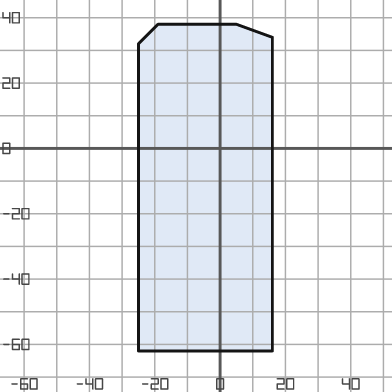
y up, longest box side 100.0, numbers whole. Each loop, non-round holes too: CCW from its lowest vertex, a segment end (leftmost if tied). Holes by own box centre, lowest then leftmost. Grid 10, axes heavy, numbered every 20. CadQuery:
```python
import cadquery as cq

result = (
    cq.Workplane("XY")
    .moveTo(-25.0, -62.0)
    .lineTo(16.0, -62.0)
    .lineTo(16.0, 34.0)
    .lineTo(5.0, 38.0)
    .lineTo(-19.0, 38.0)
    .lineTo(-25.0, 32.0)
    .close()
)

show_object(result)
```